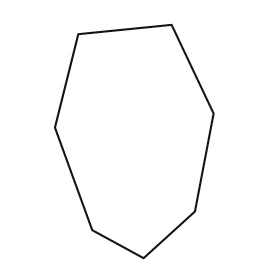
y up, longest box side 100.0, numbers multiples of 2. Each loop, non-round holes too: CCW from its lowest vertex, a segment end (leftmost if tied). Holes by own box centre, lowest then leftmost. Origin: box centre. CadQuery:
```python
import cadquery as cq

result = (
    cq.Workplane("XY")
    .moveTo(4.0, -50.0)
    .lineTo(26.0, -30.0)
    .lineTo(34.0, 12.0)
    .lineTo(16.0, 50.0)
    .lineTo(-24.0, 46.0)
    .lineTo(-34.0, 6.0)
    .lineTo(-18.0, -38.0)
    .close()
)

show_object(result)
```